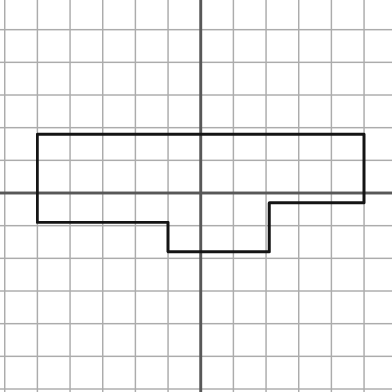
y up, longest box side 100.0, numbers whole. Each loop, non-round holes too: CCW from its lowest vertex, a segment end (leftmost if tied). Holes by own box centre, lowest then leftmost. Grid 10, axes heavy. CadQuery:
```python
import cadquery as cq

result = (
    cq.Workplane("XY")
    .moveTo(-10.0, -18.0)
    .lineTo(21.0, -18.0)
    .lineTo(21.0, -3.0)
    .lineTo(50.0, -3.0)
    .lineTo(50.0, 18.0)
    .lineTo(-50.0, 18.0)
    .lineTo(-50.0, -9.0)
    .lineTo(-10.0, -9.0)
    .close()
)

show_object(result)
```